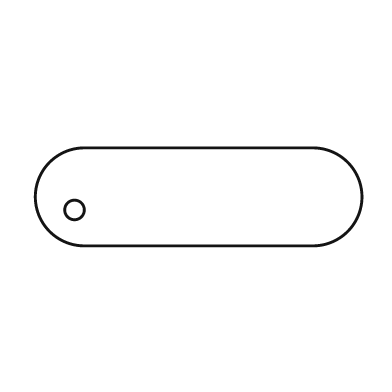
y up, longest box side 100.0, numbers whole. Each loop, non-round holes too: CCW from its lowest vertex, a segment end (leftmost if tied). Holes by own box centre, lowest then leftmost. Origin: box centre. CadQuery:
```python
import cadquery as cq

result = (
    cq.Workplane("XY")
    .moveTo(-35.0, -15.0)
    .lineTo(35.0, -15.0)
    .threePointArc((50.0, 0.0), (35.0, 15.0))
    .lineTo(-35.0, 15.0)
    .threePointArc((-50.0, 0.0), (-35.0, -15.0))
    .close()
    .moveTo(-38.0, -4.0)
    .circle(3.0)
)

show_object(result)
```